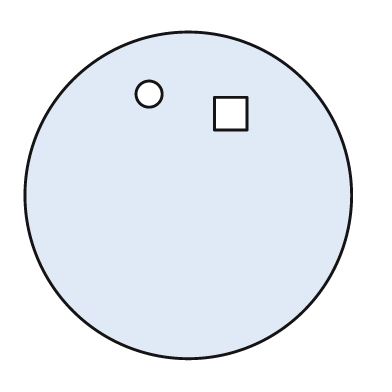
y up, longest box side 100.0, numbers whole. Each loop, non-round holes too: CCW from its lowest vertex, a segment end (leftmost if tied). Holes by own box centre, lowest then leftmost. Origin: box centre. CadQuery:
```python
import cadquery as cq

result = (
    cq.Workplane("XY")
    .moveTo(0.0, 0.0)
    .circle(50.0)
    .moveTo(8.0, 20.0)
    .lineTo(18.0, 20.0)
    .lineTo(18.0, 30.0)
    .lineTo(8.0, 30.0)
    .close()
    .moveTo(-12.0, 31.0)
    .circle(4.0)
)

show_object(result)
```